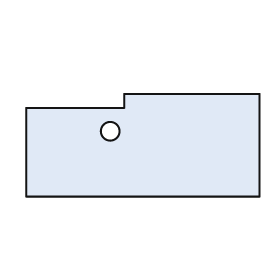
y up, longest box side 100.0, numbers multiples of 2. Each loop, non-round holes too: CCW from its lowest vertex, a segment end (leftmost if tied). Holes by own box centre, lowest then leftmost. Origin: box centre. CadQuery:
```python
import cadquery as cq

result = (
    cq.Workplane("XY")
    .moveTo(-50.0, -22.0)
    .lineTo(50.0, -22.0)
    .lineTo(50.0, 22.0)
    .lineTo(-8.0, 22.0)
    .lineTo(-8.0, 16.0)
    .lineTo(-50.0, 16.0)
    .close()
    .moveTo(-14.0, 6.0)
    .circle(4.0)
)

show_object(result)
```